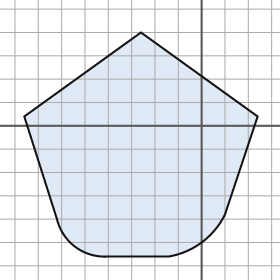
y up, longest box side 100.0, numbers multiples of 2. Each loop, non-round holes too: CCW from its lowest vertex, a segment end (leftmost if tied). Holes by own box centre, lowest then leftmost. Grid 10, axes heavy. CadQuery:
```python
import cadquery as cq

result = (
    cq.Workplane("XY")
    .moveTo(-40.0, -56.0)
    .lineTo(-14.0, -56.0)
    .threePointArc((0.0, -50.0), (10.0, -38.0))
    .lineTo(24.0, 4.0)
    .lineTo(-26.0, 40.0)
    .lineTo(-76.0, 4.0)
    .lineTo(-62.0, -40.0)
    .threePointArc((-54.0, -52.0), (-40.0, -56.0))
    .close()
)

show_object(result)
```